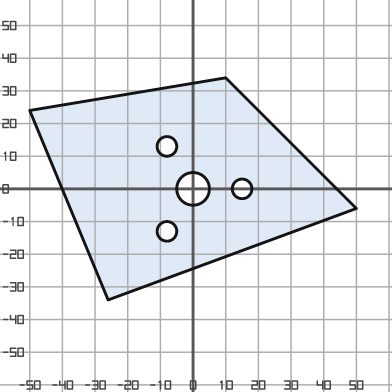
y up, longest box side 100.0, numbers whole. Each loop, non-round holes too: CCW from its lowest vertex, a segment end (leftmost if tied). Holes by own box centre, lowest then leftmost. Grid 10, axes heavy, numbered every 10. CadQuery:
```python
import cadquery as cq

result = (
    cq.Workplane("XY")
    .moveTo(-26.0, -34.0)
    .lineTo(50.0, -6.0)
    .lineTo(10.0, 34.0)
    .lineTo(-50.0, 24.0)
    .close()
    .moveTo(-8.0, -13.0)
    .circle(3.0)
    .moveTo(0.0, 0.0)
    .circle(5.0)
    .moveTo(15.0, 0.0)
    .circle(3.0)
    .moveTo(-8.0, 13.0)
    .circle(3.0)
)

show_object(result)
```